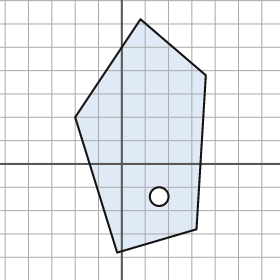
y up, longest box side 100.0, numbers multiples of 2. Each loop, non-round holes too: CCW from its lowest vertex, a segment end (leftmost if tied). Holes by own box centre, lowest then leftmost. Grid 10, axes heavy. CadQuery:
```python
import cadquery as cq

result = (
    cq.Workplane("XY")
    .moveTo(-2.0, -38.0)
    .lineTo(32.0, -28.0)
    .lineTo(36.0, 38.0)
    .lineTo(8.0, 62.0)
    .lineTo(-20.0, 20.0)
    .close()
    .moveTo(16.0, -14.0)
    .circle(4.0)
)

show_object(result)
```